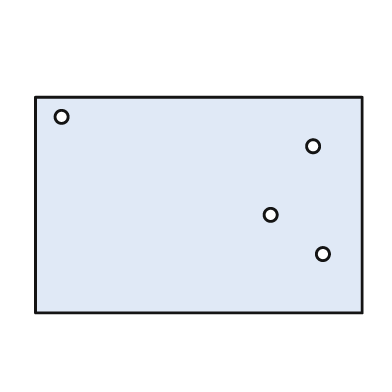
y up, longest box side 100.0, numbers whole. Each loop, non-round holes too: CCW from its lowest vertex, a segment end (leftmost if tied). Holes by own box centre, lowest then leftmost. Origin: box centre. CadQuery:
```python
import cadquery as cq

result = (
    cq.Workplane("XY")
    .moveTo(-50.0, -33.0)
    .lineTo(50.0, -33.0)
    .lineTo(50.0, 33.0)
    .lineTo(-50.0, 33.0)
    .close()
    .moveTo(38.0, -15.0)
    .circle(2.0)
    .moveTo(22.0, -3.0)
    .circle(2.0)
    .moveTo(35.0, 18.0)
    .circle(2.0)
    .moveTo(-42.0, 27.0)
    .circle(2.0)
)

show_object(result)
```